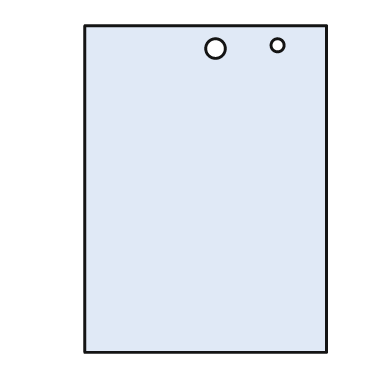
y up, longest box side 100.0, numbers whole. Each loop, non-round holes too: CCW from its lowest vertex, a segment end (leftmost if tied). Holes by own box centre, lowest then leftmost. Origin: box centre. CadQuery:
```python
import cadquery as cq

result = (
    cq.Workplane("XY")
    .moveTo(-37.0, -50.0)
    .lineTo(37.0, -50.0)
    .lineTo(37.0, 50.0)
    .lineTo(-37.0, 50.0)
    .close()
    .moveTo(3.0, 43.0)
    .circle(3.0)
    .moveTo(22.0, 44.0)
    .circle(2.0)
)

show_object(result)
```